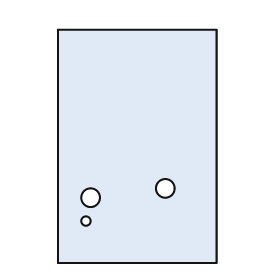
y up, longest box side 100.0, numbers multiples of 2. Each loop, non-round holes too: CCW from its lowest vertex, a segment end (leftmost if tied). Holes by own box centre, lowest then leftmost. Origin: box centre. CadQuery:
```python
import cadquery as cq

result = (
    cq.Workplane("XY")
    .moveTo(-34.0, -50.0)
    .lineTo(34.0, -50.0)
    .lineTo(34.0, 50.0)
    .lineTo(-34.0, 50.0)
    .close()
    .moveTo(-22.0, -32.0)
    .circle(2.0)
    .moveTo(-20.0, -22.0)
    .circle(4.0)
    .moveTo(12.0, -18.0)
    .circle(4.0)
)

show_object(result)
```